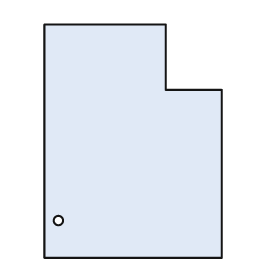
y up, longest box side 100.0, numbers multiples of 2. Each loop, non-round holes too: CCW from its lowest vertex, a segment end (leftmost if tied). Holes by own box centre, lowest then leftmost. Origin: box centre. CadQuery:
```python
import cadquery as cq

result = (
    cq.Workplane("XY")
    .moveTo(-38.0, -50.0)
    .lineTo(38.0, -50.0)
    .lineTo(38.0, 22.0)
    .lineTo(14.0, 22.0)
    .lineTo(14.0, 50.0)
    .lineTo(-38.0, 50.0)
    .close()
    .moveTo(-32.0, -34.0)
    .circle(2.0)
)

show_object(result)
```